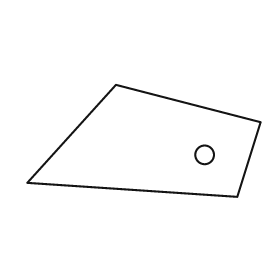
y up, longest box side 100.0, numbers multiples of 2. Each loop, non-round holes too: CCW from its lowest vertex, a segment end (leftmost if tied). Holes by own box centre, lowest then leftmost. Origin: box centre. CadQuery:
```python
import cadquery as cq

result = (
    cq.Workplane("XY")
    .moveTo(40.0, -24.0)
    .lineTo(50.0, 8.0)
    .lineTo(-12.0, 24.0)
    .lineTo(-50.0, -18.0)
    .close()
    .moveTo(26.0, -6.0)
    .circle(4.0)
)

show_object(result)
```